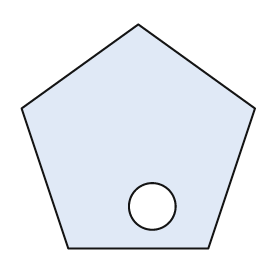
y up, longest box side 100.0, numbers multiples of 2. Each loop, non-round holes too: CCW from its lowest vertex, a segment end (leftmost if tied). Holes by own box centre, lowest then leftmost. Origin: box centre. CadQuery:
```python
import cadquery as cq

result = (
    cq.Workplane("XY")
    .moveTo(-30.0, -48.0)
    .lineTo(30.0, -48.0)
    .lineTo(50.0, 12.0)
    .lineTo(0.0, 48.0)
    .lineTo(-50.0, 12.0)
    .close()
    .moveTo(6.0, -30.0)
    .circle(10.0)
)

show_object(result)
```